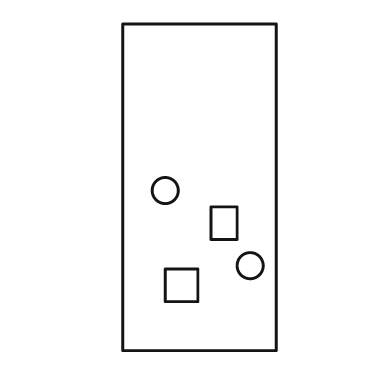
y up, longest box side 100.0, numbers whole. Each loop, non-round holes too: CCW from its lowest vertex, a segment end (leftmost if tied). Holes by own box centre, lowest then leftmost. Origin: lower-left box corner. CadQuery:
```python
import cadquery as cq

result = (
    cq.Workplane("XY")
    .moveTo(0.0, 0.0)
    .lineTo(47.0, 0.0)
    .lineTo(47.0, 100.0)
    .lineTo(0.0, 100.0)
    .close()
    .moveTo(13.0, 15.0)
    .lineTo(23.0, 15.0)
    .lineTo(23.0, 25.0)
    .lineTo(13.0, 25.0)
    .close()
    .moveTo(39.0, 26.0)
    .circle(4.0)
    .moveTo(27.0, 34.0)
    .lineTo(35.0, 34.0)
    .lineTo(35.0, 44.0)
    .lineTo(27.0, 44.0)
    .close()
    .moveTo(13.0, 49.0)
    .circle(4.0)
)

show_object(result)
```